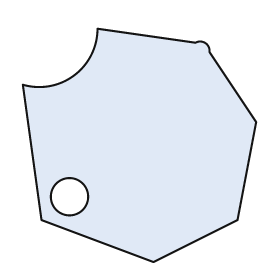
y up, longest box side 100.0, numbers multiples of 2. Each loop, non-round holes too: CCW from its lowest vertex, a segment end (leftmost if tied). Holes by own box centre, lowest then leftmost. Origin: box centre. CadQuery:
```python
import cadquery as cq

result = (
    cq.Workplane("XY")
    .moveTo(6.0, -50.0)
    .lineTo(42.0, -32.0)
    .lineTo(50.0, 10.0)
    .lineTo(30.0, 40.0)
    .threePointArc((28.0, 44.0), (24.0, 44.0))
    .lineTo(-18.0, 50.0)
    .threePointArc((-28.0, 30.0), (-50.0, 26.0))
    .lineTo(-42.0, -32.0)
    .close()
    .moveTo(-30.0, -22.0)
    .circle(8.0)
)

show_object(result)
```